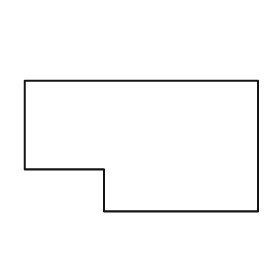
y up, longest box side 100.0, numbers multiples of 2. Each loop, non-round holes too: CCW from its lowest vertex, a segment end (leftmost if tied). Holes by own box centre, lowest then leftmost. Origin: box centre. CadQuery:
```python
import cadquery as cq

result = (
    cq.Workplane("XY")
    .moveTo(-16.0, -28.0)
    .lineTo(50.0, -28.0)
    .lineTo(50.0, 28.0)
    .lineTo(-50.0, 28.0)
    .lineTo(-50.0, -10.0)
    .lineTo(-16.0, -10.0)
    .close()
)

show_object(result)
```